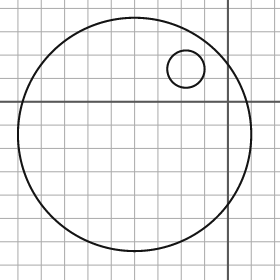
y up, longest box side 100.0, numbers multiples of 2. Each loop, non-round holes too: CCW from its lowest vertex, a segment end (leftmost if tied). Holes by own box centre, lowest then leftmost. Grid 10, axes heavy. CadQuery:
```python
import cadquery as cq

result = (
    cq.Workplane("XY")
    .moveTo(-40.0, -14.0)
    .circle(50.0)
    .moveTo(-18.0, 14.0)
    .circle(8.0)
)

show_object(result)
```